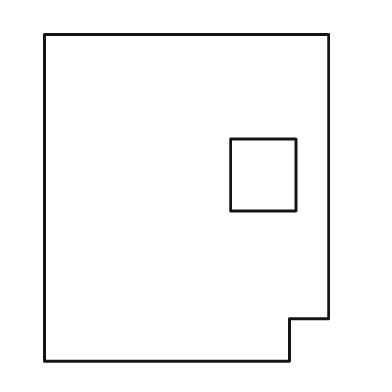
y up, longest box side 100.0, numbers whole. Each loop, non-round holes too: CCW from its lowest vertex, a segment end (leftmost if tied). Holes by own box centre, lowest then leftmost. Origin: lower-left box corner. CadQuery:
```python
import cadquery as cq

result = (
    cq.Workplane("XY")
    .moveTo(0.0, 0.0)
    .lineTo(75.0, 0.0)
    .lineTo(75.0, 13.0)
    .lineTo(87.0, 13.0)
    .lineTo(87.0, 100.0)
    .lineTo(0.0, 100.0)
    .close()
    .moveTo(57.0, 46.0)
    .lineTo(77.0, 46.0)
    .lineTo(77.0, 68.0)
    .lineTo(57.0, 68.0)
    .close()
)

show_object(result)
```